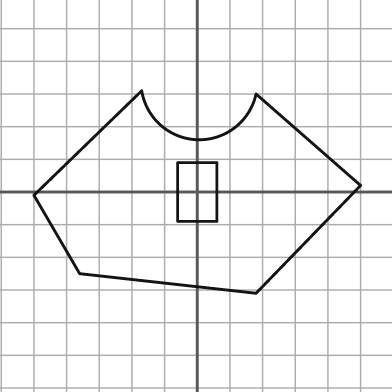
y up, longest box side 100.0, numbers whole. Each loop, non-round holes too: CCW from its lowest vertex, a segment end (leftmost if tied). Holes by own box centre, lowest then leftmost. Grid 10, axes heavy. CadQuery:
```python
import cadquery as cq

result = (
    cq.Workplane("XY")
    .moveTo(18.0, -31.0)
    .lineTo(50.0, 2.0)
    .lineTo(18.0, 30.0)
    .threePointArc((0.0, 16.0), (-17.0, 31.0))
    .lineTo(-50.0, -1.0)
    .lineTo(-36.0, -25.0)
    .close()
    .moveTo(-6.0, -9.0)
    .lineTo(6.0, -9.0)
    .lineTo(6.0, 9.0)
    .lineTo(-6.0, 9.0)
    .close()
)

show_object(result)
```